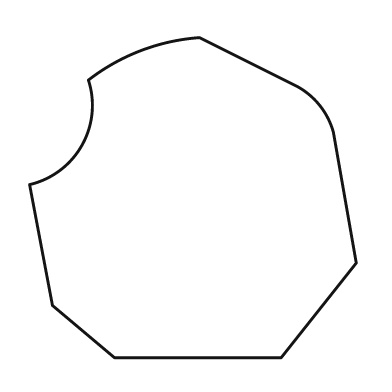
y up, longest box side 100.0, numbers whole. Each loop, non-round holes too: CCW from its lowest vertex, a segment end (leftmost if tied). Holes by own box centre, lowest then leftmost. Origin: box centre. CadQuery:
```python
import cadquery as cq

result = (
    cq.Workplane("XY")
    .moveTo(-24.0, -49.0)
    .lineTo(27.0, -49.0)
    .lineTo(50.0, -20.0)
    .lineTo(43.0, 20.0)
    .threePointArc((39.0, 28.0), (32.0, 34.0))
    .lineTo(2.0, 49.0)
    .threePointArc((-16.0, 45.0), (-32.0, 36.0))
    .threePointArc((-34.0, 16.0), (-50.0, 4.0))
    .lineTo(-43.0, -33.0)
    .close()
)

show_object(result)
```